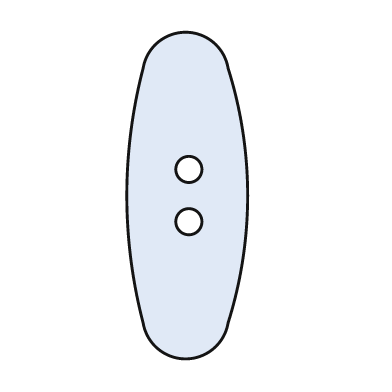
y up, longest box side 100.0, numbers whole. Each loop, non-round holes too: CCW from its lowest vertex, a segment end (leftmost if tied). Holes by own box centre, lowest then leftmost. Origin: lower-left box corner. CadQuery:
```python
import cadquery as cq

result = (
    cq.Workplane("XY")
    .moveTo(5.0, 11.0)
    .threePointArc((18.0, 0.0), (31.0, 11.0))
    .threePointArc((37.0, 50.0), (31.0, 89.0))
    .threePointArc((18.0, 100.0), (5.0, 89.0))
    .threePointArc((0.0, 50.0), (5.0, 11.0))
    .close()
    .moveTo(19.0, 42.0)
    .circle(4.0)
    .moveTo(19.0, 58.0)
    .circle(4.0)
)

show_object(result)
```